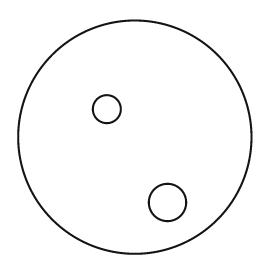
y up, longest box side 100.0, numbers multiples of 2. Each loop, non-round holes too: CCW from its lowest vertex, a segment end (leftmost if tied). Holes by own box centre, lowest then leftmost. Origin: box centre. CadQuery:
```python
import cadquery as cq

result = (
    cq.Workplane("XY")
    .moveTo(0.0, 0.0)
    .circle(50.0)
    .moveTo(14.0, -28.0)
    .circle(8.0)
    .moveTo(-12.0, 12.0)
    .circle(6.0)
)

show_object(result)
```